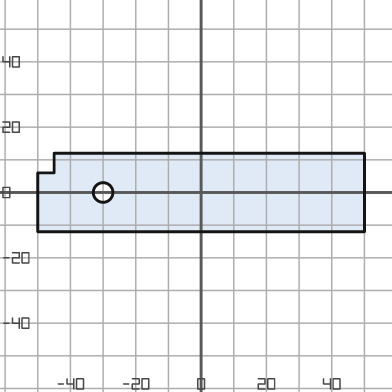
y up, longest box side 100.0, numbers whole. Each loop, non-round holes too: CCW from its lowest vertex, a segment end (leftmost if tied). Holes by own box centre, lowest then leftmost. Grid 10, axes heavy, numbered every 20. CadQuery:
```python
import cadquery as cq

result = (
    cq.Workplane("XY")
    .moveTo(-50.0, -12.0)
    .lineTo(50.0, -12.0)
    .lineTo(50.0, 12.0)
    .lineTo(-45.0, 12.0)
    .lineTo(-45.0, 6.0)
    .lineTo(-50.0, 6.0)
    .close()
    .moveTo(-30.0, 0.0)
    .circle(3.0)
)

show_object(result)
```